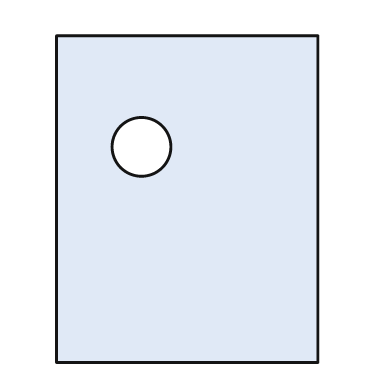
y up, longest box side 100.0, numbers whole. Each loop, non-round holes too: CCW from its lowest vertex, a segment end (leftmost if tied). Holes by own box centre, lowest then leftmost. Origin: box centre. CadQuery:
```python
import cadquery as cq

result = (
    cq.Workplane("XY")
    .moveTo(-40.0, -50.0)
    .lineTo(40.0, -50.0)
    .lineTo(40.0, 50.0)
    .lineTo(-40.0, 50.0)
    .close()
    .moveTo(-14.0, 16.0)
    .circle(9.0)
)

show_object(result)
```